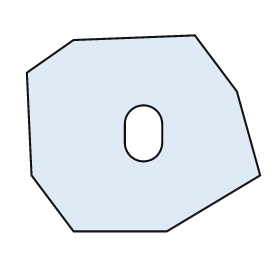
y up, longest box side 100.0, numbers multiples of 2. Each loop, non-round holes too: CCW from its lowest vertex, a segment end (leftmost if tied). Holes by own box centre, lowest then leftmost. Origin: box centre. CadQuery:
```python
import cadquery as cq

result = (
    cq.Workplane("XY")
    .moveTo(-30.0, -42.0)
    .lineTo(10.0, -42.0)
    .lineTo(50.0, -18.0)
    .lineTo(40.0, 18.0)
    .lineTo(22.0, 42.0)
    .lineTo(-30.0, 40.0)
    .lineTo(-50.0, 26.0)
    .lineTo(-48.0, -18.0)
    .close()
    .moveTo(-8.0, -4.0)
    .threePointArc((0.0, -12.0), (8.0, -4.0))
    .lineTo(8.0, 4.0)
    .threePointArc((0.0, 12.0), (-8.0, 4.0))
    .close()
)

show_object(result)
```